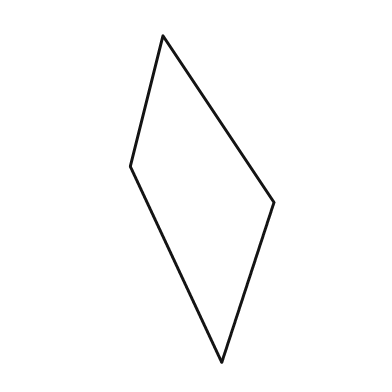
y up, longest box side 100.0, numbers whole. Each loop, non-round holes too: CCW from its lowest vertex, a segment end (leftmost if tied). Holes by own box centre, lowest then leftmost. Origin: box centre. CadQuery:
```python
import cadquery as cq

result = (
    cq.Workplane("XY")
    .moveTo(6.0, -50.0)
    .lineTo(22.0, -1.0)
    .lineTo(-12.0, 50.0)
    .lineTo(-22.0, 10.0)
    .close()
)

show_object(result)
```